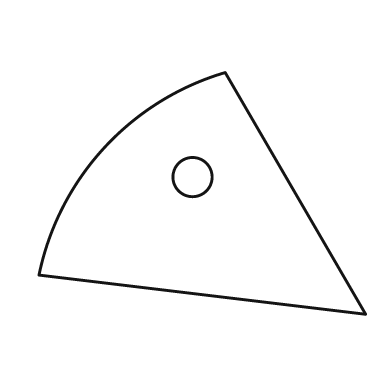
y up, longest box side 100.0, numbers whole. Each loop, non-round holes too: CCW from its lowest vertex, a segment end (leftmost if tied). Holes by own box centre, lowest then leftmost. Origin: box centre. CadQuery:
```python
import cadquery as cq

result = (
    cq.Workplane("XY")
    .moveTo(50.0, -37.0)
    .lineTo(7.0, 37.0)
    .threePointArc((-30.0, 14.0), (-50.0, -25.0))
    .close()
    .moveTo(-3.0, 5.0)
    .circle(6.0)
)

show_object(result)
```